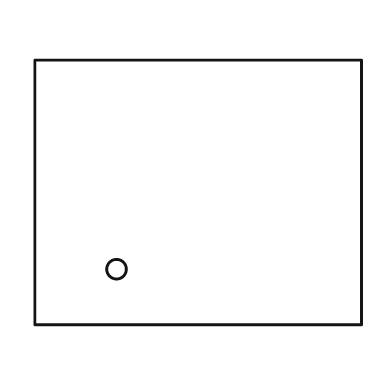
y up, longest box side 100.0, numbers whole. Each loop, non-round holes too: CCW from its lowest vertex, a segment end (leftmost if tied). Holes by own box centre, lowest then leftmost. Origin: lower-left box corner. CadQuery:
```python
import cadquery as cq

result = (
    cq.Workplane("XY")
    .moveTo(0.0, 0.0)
    .lineTo(100.0, 0.0)
    .lineTo(100.0, 81.0)
    .lineTo(0.0, 81.0)
    .close()
    .moveTo(25.0, 17.0)
    .circle(3.0)
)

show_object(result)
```